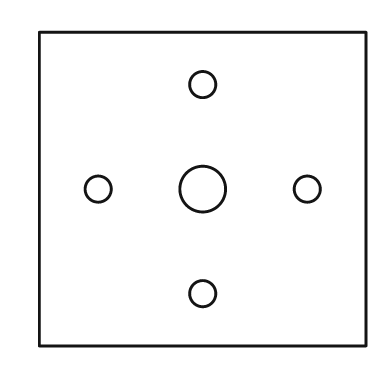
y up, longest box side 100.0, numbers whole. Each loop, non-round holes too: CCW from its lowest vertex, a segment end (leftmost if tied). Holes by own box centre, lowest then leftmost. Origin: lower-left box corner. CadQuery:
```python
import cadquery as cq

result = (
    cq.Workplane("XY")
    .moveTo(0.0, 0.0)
    .lineTo(100.0, 0.0)
    .lineTo(100.0, 96.0)
    .lineTo(0.0, 96.0)
    .close()
    .moveTo(50.0, 16.0)
    .circle(4.0)
    .moveTo(18.0, 48.0)
    .circle(4.0)
    .moveTo(50.0, 48.0)
    .circle(7.0)
    .moveTo(82.0, 48.0)
    .circle(4.0)
    .moveTo(50.0, 80.0)
    .circle(4.0)
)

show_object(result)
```